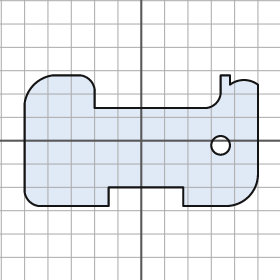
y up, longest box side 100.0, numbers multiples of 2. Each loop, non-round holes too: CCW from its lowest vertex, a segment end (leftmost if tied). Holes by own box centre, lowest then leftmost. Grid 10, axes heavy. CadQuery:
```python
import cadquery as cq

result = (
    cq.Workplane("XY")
    .moveTo(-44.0, -28.0)
    .lineTo(-14.0, -28.0)
    .lineTo(-14.0, -20.0)
    .lineTo(18.0, -20.0)
    .lineTo(18.0, -28.0)
    .lineTo(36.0, -28.0)
    .threePointArc((46.0, -24.0), (50.0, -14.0))
    .lineTo(50.0, 24.0)
    .threePointArc((44.0, 26.0), (38.0, 24.0))
    .lineTo(38.0, 28.0)
    .lineTo(34.0, 28.0)
    .lineTo(34.0, 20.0)
    .threePointArc((32.0, 16.0), (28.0, 14.0))
    .lineTo(-20.0, 14.0)
    .lineTo(-20.0, 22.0)
    .threePointArc((-22.0, 26.0), (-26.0, 28.0))
    .lineTo(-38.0, 28.0)
    .threePointArc((-46.0, 24.0), (-50.0, 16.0))
    .lineTo(-50.0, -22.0)
    .threePointArc((-48.0, -26.0), (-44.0, -28.0))
    .close()
    .moveTo(34.0, -2.0)
    .circle(4.0)
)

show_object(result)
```